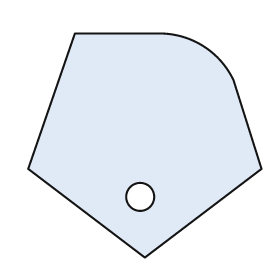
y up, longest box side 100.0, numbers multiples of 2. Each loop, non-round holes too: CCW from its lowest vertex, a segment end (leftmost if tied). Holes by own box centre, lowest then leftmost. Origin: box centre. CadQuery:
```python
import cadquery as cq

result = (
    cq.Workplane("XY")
    .moveTo(0.0, -48.0)
    .lineTo(50.0, -10.0)
    .lineTo(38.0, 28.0)
    .threePointArc((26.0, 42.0), (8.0, 48.0))
    .lineTo(-30.0, 48.0)
    .lineTo(-50.0, -10.0)
    .close()
    .moveTo(-2.0, -22.0)
    .circle(6.0)
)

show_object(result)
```